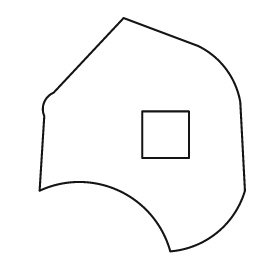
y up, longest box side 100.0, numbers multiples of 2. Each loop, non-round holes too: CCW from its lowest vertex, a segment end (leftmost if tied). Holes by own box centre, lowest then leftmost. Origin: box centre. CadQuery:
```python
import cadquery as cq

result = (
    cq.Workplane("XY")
    .moveTo(12.0, -50.0)
    .threePointArc((32.0, -42.0), (44.0, -24.0))
    .lineTo(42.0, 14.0)
    .threePointArc((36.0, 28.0), (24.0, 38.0))
    .lineTo(-8.0, 50.0)
    .lineTo(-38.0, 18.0)
    .threePointArc((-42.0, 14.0), (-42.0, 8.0))
    .lineTo(-44.0, -24.0)
    .threePointArc((-10.0, -24.0), (12.0, -50.0))
    .close()
    .moveTo(0.0, -10.0)
    .lineTo(20.0, -10.0)
    .lineTo(20.0, 10.0)
    .lineTo(0.0, 10.0)
    .close()
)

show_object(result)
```